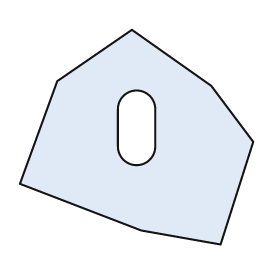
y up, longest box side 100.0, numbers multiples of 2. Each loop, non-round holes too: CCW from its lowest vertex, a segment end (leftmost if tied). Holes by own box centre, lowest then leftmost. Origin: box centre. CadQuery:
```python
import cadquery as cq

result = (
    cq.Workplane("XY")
    .moveTo(36.0, -46.0)
    .lineTo(50.0, -2.0)
    .lineTo(32.0, 22.0)
    .lineTo(-2.0, 46.0)
    .lineTo(-34.0, 24.0)
    .lineTo(-50.0, -20.0)
    .lineTo(2.0, -40.0)
    .close()
    .moveTo(-8.0, -4.0)
    .threePointArc((0.0, -12.0), (8.0, -4.0))
    .lineTo(8.0, 12.0)
    .threePointArc((0.0, 20.0), (-8.0, 12.0))
    .close()
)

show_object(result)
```